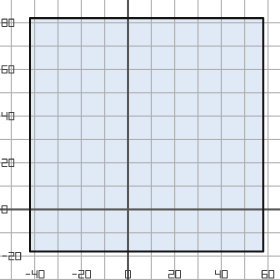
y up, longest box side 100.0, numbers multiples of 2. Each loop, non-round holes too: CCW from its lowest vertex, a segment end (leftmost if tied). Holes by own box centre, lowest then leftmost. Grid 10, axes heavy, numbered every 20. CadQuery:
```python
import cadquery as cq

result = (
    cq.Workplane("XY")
    .moveTo(-42.0, -18.0)
    .lineTo(58.0, -18.0)
    .lineTo(58.0, 82.0)
    .lineTo(-42.0, 82.0)
    .close()
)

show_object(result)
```